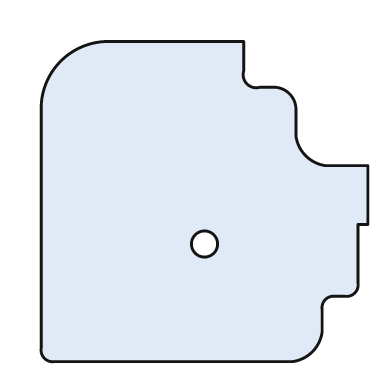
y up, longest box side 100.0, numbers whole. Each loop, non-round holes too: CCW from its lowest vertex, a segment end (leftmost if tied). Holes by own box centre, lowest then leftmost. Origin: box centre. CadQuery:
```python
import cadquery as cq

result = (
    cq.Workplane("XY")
    .moveTo(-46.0, -49.0)
    .lineTo(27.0, -49.0)
    .threePointArc((33.0, -46.0), (36.0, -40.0))
    .lineTo(36.0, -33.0)
    .threePointArc((37.0, -30.0), (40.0, -29.0))
    .lineTo(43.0, -29.0)
    .threePointArc((46.0, -28.0), (47.0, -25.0))
    .lineTo(47.0, -7.0)
    .lineTo(50.0, -7.0)
    .lineTo(50.0, 11.0)
    .lineTo(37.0, 11.0)
    .threePointArc((31.0, 14.0), (28.0, 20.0))
    .lineTo(28.0, 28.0)
    .threePointArc((26.0, 33.0), (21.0, 35.0))
    .lineTo(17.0, 35.0)
    .threePointArc((13.0, 36.0), (12.0, 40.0))
    .lineTo(12.0, 49.0)
    .lineTo(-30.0, 49.0)
    .threePointArc((-44.0, 43.0), (-50.0, 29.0))
    .lineTo(-50.0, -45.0)
    .threePointArc((-49.0, -48.0), (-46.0, -49.0))
    .close()
    .moveTo(0.0, -13.0)
    .circle(4.0)
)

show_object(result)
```